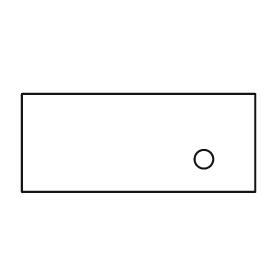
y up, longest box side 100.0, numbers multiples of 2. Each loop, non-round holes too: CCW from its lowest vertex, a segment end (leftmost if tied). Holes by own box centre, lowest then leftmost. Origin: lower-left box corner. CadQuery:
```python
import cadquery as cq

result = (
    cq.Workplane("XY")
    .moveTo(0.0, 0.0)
    .lineTo(100.0, 0.0)
    .lineTo(100.0, 42.0)
    .lineTo(0.0, 42.0)
    .close()
    .moveTo(78.0, 14.0)
    .circle(4.0)
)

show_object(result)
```